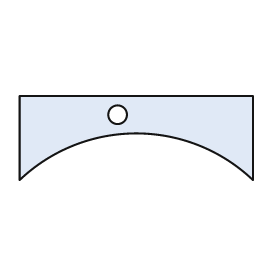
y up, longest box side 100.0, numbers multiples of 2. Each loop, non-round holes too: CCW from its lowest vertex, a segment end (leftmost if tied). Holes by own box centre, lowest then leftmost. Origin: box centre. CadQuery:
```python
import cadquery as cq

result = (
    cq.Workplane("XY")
    .moveTo(-50.0, -18.0)
    .threePointArc((0.0, 2.0), (50.0, -18.0))
    .lineTo(50.0, 18.0)
    .lineTo(-50.0, 18.0)
    .close()
    .moveTo(-8.0, 10.0)
    .circle(4.0)
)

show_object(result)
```